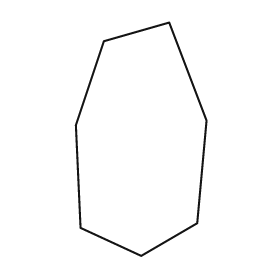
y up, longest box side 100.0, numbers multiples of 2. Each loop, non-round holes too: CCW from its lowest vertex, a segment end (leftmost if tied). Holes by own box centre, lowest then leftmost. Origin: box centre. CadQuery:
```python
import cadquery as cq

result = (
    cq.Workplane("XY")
    .moveTo(0.0, -50.0)
    .lineTo(24.0, -36.0)
    .lineTo(28.0, 8.0)
    .lineTo(12.0, 50.0)
    .lineTo(-16.0, 42.0)
    .lineTo(-28.0, 6.0)
    .lineTo(-26.0, -38.0)
    .close()
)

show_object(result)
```